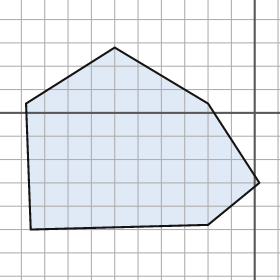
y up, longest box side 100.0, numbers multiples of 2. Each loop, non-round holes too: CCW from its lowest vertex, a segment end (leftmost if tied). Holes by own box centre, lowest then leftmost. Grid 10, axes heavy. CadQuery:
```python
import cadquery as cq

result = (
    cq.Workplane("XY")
    .moveTo(-96.0, -50.0)
    .lineTo(-20.0, -48.0)
    .lineTo(2.0, -30.0)
    .lineTo(-20.0, 4.0)
    .lineTo(-60.0, 28.0)
    .lineTo(-98.0, 4.0)
    .close()
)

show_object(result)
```